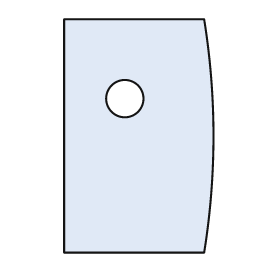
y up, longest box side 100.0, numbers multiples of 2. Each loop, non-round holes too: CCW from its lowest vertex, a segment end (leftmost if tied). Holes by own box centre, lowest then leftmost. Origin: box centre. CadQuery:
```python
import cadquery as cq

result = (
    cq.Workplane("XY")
    .moveTo(-32.0, -50.0)
    .lineTo(28.0, -50.0)
    .threePointArc((32.0, 0.0), (28.0, 50.0))
    .lineTo(-32.0, 50.0)
    .close()
    .moveTo(-6.0, 16.0)
    .circle(8.0)
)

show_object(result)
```